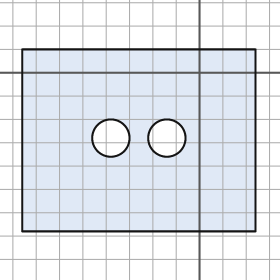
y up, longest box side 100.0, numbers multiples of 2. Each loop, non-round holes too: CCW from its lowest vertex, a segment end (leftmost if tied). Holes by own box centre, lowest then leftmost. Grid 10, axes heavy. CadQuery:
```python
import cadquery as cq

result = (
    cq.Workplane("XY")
    .moveTo(-76.0, -68.0)
    .lineTo(24.0, -68.0)
    .lineTo(24.0, 10.0)
    .lineTo(-76.0, 10.0)
    .close()
    .moveTo(-38.0, -28.0)
    .circle(8.0)
    .moveTo(-14.0, -28.0)
    .circle(8.0)
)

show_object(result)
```